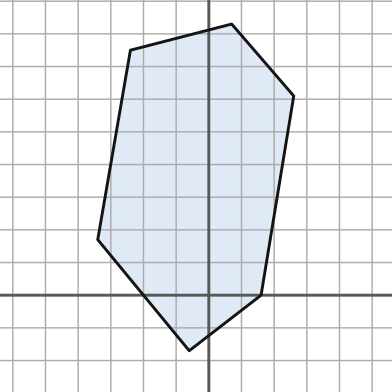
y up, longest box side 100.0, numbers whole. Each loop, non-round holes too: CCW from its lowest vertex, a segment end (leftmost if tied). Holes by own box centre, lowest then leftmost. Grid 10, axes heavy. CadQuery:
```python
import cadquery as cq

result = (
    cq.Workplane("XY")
    .moveTo(-6.0, -17.0)
    .lineTo(16.0, 0.0)
    .lineTo(26.0, 61.0)
    .lineTo(7.0, 83.0)
    .lineTo(-24.0, 75.0)
    .lineTo(-34.0, 17.0)
    .close()
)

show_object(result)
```